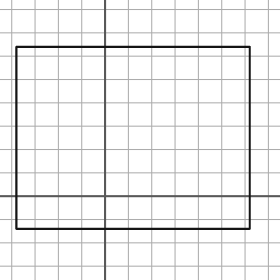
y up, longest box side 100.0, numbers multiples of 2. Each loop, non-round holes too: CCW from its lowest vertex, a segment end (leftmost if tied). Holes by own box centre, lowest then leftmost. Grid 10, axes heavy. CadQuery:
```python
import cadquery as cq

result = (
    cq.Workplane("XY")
    .moveTo(-38.0, -14.0)
    .lineTo(62.0, -14.0)
    .lineTo(62.0, 64.0)
    .lineTo(-38.0, 64.0)
    .close()
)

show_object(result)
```